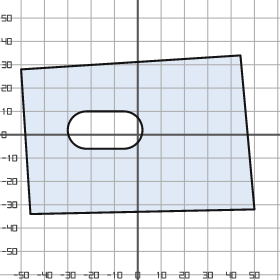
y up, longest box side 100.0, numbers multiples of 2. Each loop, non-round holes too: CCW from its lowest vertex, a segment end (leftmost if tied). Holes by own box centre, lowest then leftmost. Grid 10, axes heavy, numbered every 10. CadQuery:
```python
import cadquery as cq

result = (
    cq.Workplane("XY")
    .moveTo(-46.0, -34.0)
    .lineTo(50.0, -32.0)
    .lineTo(44.0, 34.0)
    .lineTo(-50.0, 28.0)
    .close()
    .moveTo(-22.0, -6.0)
    .lineTo(-6.0, -6.0)
    .threePointArc((2.0, 2.0), (-6.0, 10.0))
    .lineTo(-22.0, 10.0)
    .threePointArc((-30.0, 2.0), (-22.0, -6.0))
    .close()
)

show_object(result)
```